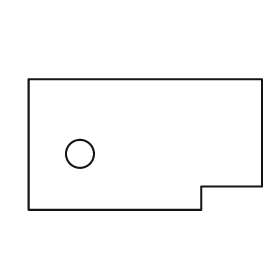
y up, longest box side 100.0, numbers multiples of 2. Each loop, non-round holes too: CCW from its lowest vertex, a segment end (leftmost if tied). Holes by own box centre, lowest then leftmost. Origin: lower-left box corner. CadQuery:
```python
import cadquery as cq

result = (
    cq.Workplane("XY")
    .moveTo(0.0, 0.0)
    .lineTo(74.0, 0.0)
    .lineTo(74.0, 10.0)
    .lineTo(100.0, 10.0)
    .lineTo(100.0, 56.0)
    .lineTo(0.0, 56.0)
    .close()
    .moveTo(22.0, 24.0)
    .circle(6.0)
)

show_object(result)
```